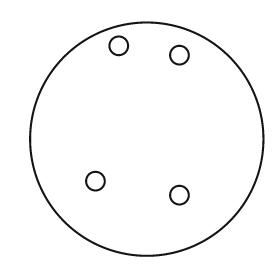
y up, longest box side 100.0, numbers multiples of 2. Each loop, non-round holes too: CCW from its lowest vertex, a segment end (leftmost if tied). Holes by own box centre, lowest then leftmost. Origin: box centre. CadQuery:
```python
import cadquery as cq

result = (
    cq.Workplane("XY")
    .moveTo(0.0, 0.0)
    .circle(50.0)
    .moveTo(14.0, -24.0)
    .circle(4.0)
    .moveTo(-22.0, -18.0)
    .circle(4.0)
    .moveTo(14.0, 36.0)
    .circle(4.0)
    .moveTo(-12.0, 40.0)
    .circle(4.0)
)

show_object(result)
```